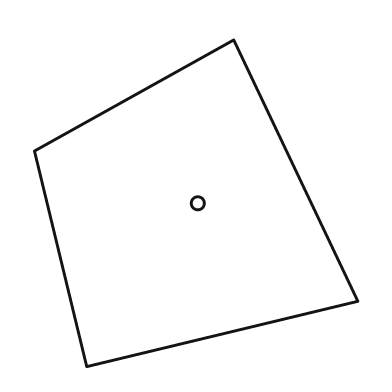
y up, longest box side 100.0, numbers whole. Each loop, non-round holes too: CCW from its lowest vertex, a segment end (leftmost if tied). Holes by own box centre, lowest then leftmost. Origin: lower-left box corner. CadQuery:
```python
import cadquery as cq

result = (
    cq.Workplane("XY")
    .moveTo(16.0, 0.0)
    .lineTo(99.0, 20.0)
    .lineTo(61.0, 100.0)
    .lineTo(0.0, 66.0)
    .close()
    .moveTo(50.0, 50.0)
    .circle(2.0)
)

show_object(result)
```